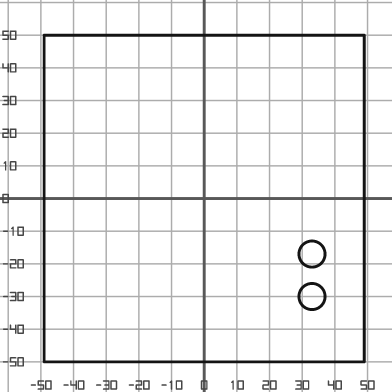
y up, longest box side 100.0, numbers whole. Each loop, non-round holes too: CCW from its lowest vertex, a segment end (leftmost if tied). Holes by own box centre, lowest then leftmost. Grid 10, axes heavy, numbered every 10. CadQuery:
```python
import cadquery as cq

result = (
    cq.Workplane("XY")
    .moveTo(-49.0, -50.0)
    .lineTo(49.0, -50.0)
    .lineTo(49.0, 50.0)
    .lineTo(-49.0, 50.0)
    .close()
    .moveTo(33.0, -30.0)
    .circle(4.0)
    .moveTo(33.0, -17.0)
    .circle(4.0)
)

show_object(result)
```